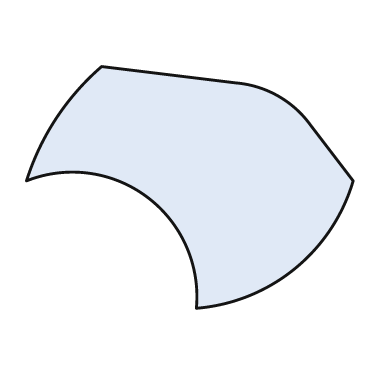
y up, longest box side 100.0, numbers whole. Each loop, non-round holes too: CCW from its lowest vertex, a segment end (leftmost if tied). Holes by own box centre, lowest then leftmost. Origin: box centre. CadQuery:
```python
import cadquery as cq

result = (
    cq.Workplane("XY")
    .moveTo(2.0, -37.0)
    .threePointArc((32.0, -25.0), (50.0, 2.0))
    .lineTo(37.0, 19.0)
    .threePointArc((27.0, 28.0), (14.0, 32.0))
    .lineTo(-27.0, 37.0)
    .threePointArc((-41.0, 21.0), (-50.0, 2.0))
    .threePointArc((-13.0, -3.0), (2.0, -37.0))
    .close()
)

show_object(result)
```